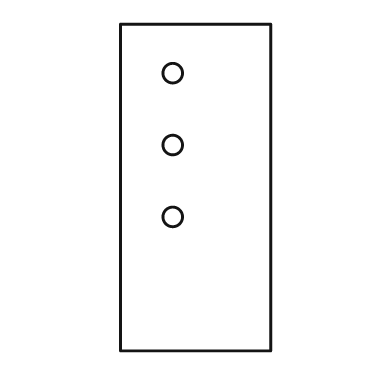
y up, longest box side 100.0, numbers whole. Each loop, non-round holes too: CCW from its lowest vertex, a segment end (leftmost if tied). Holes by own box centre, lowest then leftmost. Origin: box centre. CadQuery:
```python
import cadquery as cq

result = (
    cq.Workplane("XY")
    .moveTo(-23.0, -50.0)
    .lineTo(23.0, -50.0)
    .lineTo(23.0, 50.0)
    .lineTo(-23.0, 50.0)
    .close()
    .moveTo(-7.0, -9.0)
    .circle(3.0)
    .moveTo(-7.0, 13.0)
    .circle(3.0)
    .moveTo(-7.0, 35.0)
    .circle(3.0)
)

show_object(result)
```